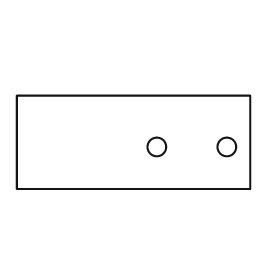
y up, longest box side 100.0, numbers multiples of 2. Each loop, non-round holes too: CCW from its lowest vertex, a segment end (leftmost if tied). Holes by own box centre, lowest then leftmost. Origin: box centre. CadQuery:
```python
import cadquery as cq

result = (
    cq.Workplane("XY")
    .moveTo(-50.0, -20.0)
    .lineTo(50.0, -20.0)
    .lineTo(50.0, 20.0)
    .lineTo(-50.0, 20.0)
    .close()
    .moveTo(10.0, -2.0)
    .circle(4.0)
    .moveTo(40.0, -2.0)
    .circle(4.0)
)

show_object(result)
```